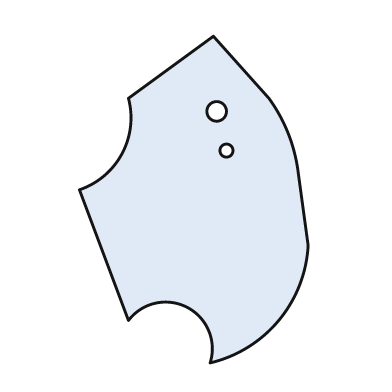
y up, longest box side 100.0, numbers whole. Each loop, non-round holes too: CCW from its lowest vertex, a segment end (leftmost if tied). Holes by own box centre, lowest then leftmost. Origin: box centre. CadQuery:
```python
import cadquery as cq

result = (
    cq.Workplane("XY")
    .moveTo(5.0, -50.0)
    .threePointArc((26.0, -37.0), (35.0, -14.0))
    .lineTo(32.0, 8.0)
    .threePointArc((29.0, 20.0), (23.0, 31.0))
    .lineTo(6.0, 50.0)
    .lineTo(-20.0, 31.0)
    .threePointArc((-22.0, 14.0), (-35.0, 3.0))
    .lineTo(-20.0, -37.0)
    .threePointArc((-2.0, -33.0), (5.0, -50.0))
    .close()
    .moveTo(10.0, 15.0)
    .circle(2.0)
    .moveTo(7.0, 27.0)
    .circle(3.0)
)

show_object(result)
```